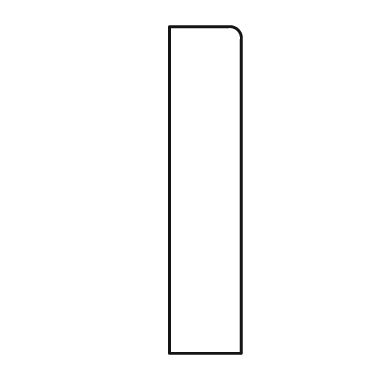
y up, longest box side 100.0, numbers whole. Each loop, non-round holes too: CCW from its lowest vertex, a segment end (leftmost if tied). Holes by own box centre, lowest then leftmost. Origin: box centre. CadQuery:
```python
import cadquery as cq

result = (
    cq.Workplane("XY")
    .moveTo(-11.0, -50.0)
    .lineTo(11.0, -50.0)
    .lineTo(11.0, 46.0)
    .threePointArc((10.0, 49.0), (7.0, 50.0))
    .lineTo(-11.0, 50.0)
    .close()
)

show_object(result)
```